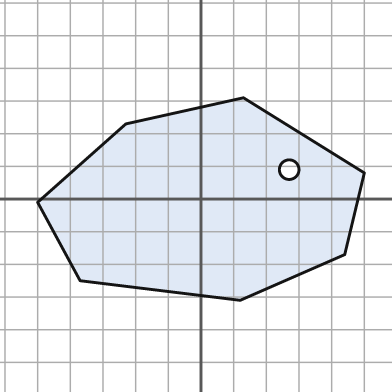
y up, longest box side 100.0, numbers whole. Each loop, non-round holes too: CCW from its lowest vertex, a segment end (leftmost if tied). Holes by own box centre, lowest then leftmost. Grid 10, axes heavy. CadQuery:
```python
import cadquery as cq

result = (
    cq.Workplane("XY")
    .moveTo(12.0, -31.0)
    .lineTo(44.0, -17.0)
    .lineTo(50.0, 8.0)
    .lineTo(13.0, 31.0)
    .lineTo(-23.0, 23.0)
    .lineTo(-50.0, -1.0)
    .lineTo(-37.0, -25.0)
    .close()
    .moveTo(27.0, 9.0)
    .circle(3.0)
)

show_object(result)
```